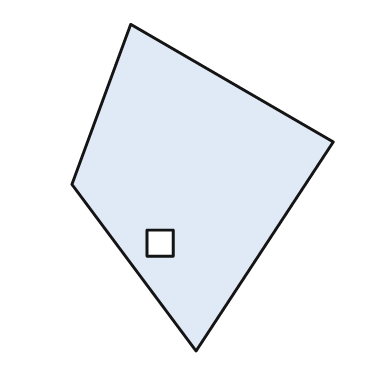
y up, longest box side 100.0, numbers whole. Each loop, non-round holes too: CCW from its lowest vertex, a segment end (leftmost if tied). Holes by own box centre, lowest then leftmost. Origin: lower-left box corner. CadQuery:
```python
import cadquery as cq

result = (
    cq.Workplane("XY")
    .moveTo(38.0, 0.0)
    .lineTo(80.0, 64.0)
    .lineTo(18.0, 100.0)
    .lineTo(0.0, 51.0)
    .close()
    .moveTo(23.0, 29.0)
    .lineTo(31.0, 29.0)
    .lineTo(31.0, 37.0)
    .lineTo(23.0, 37.0)
    .close()
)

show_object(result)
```